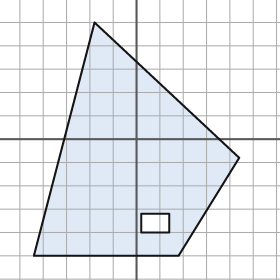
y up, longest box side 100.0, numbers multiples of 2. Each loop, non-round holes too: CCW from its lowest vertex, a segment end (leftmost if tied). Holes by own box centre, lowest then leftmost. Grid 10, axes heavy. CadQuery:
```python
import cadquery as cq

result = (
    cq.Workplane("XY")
    .moveTo(-44.0, -50.0)
    .lineTo(18.0, -50.0)
    .lineTo(44.0, -8.0)
    .lineTo(-18.0, 50.0)
    .close()
    .moveTo(2.0, -40.0)
    .lineTo(14.0, -40.0)
    .lineTo(14.0, -32.0)
    .lineTo(2.0, -32.0)
    .close()
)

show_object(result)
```